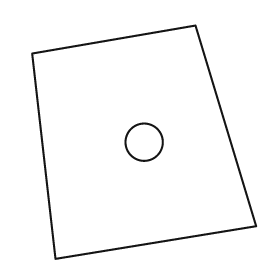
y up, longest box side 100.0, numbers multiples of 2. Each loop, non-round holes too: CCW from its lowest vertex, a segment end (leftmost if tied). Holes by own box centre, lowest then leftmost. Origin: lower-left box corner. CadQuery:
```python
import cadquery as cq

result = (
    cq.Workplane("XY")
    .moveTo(10.0, 0.0)
    .lineTo(96.0, 14.0)
    .lineTo(70.0, 100.0)
    .lineTo(0.0, 88.0)
    .close()
    .moveTo(48.0, 50.0)
    .circle(8.0)
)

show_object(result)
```